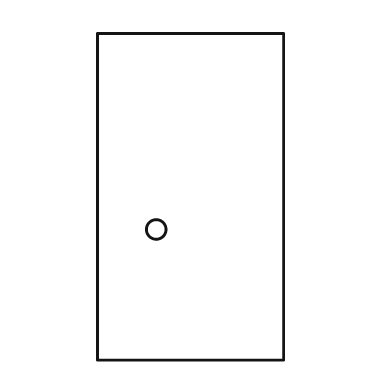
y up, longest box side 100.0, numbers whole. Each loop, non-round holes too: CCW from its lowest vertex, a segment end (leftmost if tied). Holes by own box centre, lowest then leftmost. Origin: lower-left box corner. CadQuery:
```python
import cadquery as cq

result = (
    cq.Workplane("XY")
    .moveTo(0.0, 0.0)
    .lineTo(57.0, 0.0)
    .lineTo(57.0, 100.0)
    .lineTo(0.0, 100.0)
    .close()
    .moveTo(18.0, 40.0)
    .circle(3.0)
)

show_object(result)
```